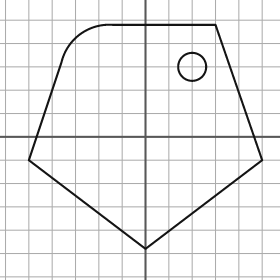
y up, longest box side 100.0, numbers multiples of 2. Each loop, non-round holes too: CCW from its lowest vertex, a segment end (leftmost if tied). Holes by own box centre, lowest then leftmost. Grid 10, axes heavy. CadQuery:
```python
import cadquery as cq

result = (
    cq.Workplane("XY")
    .moveTo(0.0, -48.0)
    .lineTo(50.0, -10.0)
    .lineTo(30.0, 48.0)
    .lineTo(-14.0, 48.0)
    .threePointArc((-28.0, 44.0), (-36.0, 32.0))
    .lineTo(-50.0, -10.0)
    .close()
    .moveTo(20.0, 30.0)
    .circle(6.0)
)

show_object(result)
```